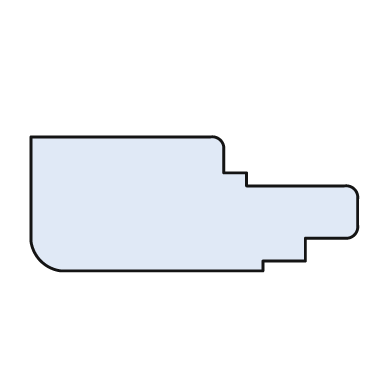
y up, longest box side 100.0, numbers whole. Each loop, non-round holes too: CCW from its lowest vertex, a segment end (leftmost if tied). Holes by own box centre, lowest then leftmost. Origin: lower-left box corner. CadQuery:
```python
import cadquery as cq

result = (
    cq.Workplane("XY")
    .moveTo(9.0, 0.0)
    .lineTo(71.0, 0.0)
    .lineTo(71.0, 3.0)
    .lineTo(84.0, 3.0)
    .lineTo(84.0, 10.0)
    .lineTo(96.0, 10.0)
    .threePointArc((99.0, 11.0), (100.0, 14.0))
    .lineTo(100.0, 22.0)
    .threePointArc((99.0, 25.0), (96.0, 26.0))
    .lineTo(66.0, 26.0)
    .lineTo(66.0, 30.0)
    .lineTo(59.0, 30.0)
    .lineTo(59.0, 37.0)
    .threePointArc((58.0, 40.0), (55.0, 41.0))
    .lineTo(0.0, 41.0)
    .lineTo(0.0, 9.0)
    .threePointArc((3.0, 3.0), (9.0, 0.0))
    .close()
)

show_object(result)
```